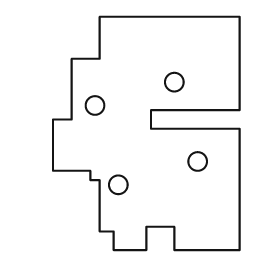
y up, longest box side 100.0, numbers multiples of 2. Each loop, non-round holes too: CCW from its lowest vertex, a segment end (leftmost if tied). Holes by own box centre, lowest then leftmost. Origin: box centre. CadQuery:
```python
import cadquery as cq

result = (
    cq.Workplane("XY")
    .moveTo(-14.0, -50.0)
    .lineTo(0.0, -50.0)
    .lineTo(0.0, -40.0)
    .lineTo(12.0, -40.0)
    .lineTo(12.0, -50.0)
    .lineTo(40.0, -50.0)
    .lineTo(40.0, 2.0)
    .lineTo(2.0, 2.0)
    .lineTo(2.0, 10.0)
    .lineTo(40.0, 10.0)
    .lineTo(40.0, 50.0)
    .lineTo(-20.0, 50.0)
    .lineTo(-20.0, 32.0)
    .lineTo(-32.0, 32.0)
    .lineTo(-32.0, 6.0)
    .lineTo(-40.0, 6.0)
    .lineTo(-40.0, -16.0)
    .lineTo(-24.0, -16.0)
    .lineTo(-24.0, -20.0)
    .lineTo(-20.0, -20.0)
    .lineTo(-20.0, -42.0)
    .lineTo(-14.0, -42.0)
    .close()
    .moveTo(-12.0, -22.0)
    .circle(4.0)
    .moveTo(22.0, -12.0)
    .circle(4.0)
    .moveTo(-22.0, 12.0)
    .circle(4.0)
    .moveTo(12.0, 22.0)
    .circle(4.0)
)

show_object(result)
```